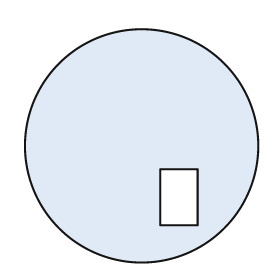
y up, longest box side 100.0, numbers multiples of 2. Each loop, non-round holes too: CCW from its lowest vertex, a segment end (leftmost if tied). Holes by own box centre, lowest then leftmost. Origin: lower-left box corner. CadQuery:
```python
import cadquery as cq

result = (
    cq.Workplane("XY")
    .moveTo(50.0, 50.0)
    .circle(50.0)
    .moveTo(58.0, 16.0)
    .lineTo(74.0, 16.0)
    .lineTo(74.0, 40.0)
    .lineTo(58.0, 40.0)
    .close()
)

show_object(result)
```